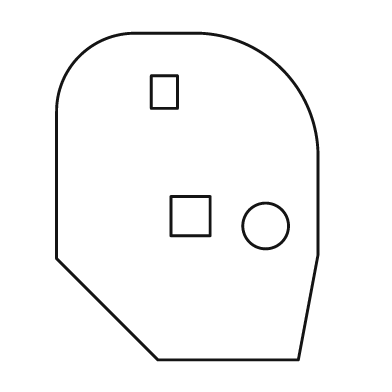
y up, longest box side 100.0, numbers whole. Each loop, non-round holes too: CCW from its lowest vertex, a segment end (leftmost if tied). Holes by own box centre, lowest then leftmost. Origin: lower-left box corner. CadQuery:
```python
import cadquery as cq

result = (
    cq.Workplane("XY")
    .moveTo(31.0, 0.0)
    .lineTo(74.0, 0.0)
    .lineTo(80.0, 32.0)
    .lineTo(80.0, 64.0)
    .threePointArc((69.0, 89.0), (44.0, 100.0))
    .lineTo(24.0, 100.0)
    .threePointArc((7.0, 93.0), (0.0, 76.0))
    .lineTo(0.0, 31.0)
    .close()
    .moveTo(64.0, 41.0)
    .circle(7.0)
    .moveTo(35.0, 38.0)
    .lineTo(47.0, 38.0)
    .lineTo(47.0, 50.0)
    .lineTo(35.0, 50.0)
    .close()
    .moveTo(29.0, 77.0)
    .lineTo(37.0, 77.0)
    .lineTo(37.0, 87.0)
    .lineTo(29.0, 87.0)
    .close()
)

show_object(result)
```